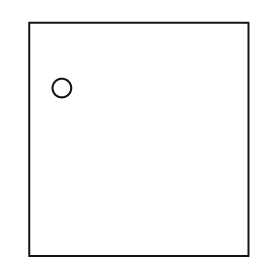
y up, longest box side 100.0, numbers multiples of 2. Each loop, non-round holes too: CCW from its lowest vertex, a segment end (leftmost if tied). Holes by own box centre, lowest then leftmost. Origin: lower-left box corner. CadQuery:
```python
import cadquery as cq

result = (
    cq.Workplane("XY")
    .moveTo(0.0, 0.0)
    .lineTo(94.0, 0.0)
    .lineTo(94.0, 100.0)
    .lineTo(0.0, 100.0)
    .close()
    .moveTo(14.0, 72.0)
    .circle(4.0)
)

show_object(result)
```